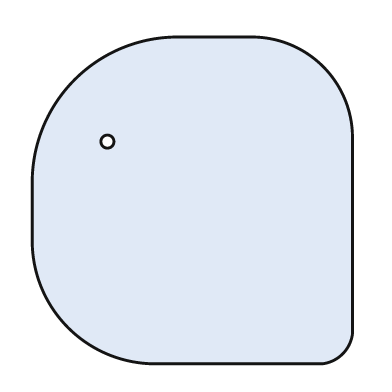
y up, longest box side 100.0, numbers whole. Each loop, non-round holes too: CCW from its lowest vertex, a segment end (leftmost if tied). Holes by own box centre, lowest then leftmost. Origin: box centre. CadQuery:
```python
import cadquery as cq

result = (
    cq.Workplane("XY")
    .moveTo(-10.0, -50.0)
    .lineTo(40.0, -50.0)
    .threePointArc((46.0, -47.0), (49.0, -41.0))
    .lineTo(49.0, 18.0)
    .threePointArc((40.0, 41.0), (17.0, 50.0))
    .lineTo(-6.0, 50.0)
    .threePointArc((-36.0, 37.0), (-49.0, 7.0))
    .lineTo(-49.0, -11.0)
    .threePointArc((-38.0, -39.0), (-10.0, -50.0))
    .close()
    .moveTo(-26.0, 18.0)
    .circle(2.0)
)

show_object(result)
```